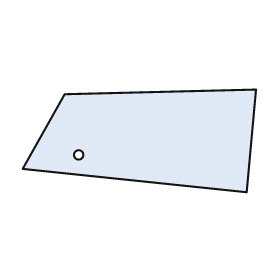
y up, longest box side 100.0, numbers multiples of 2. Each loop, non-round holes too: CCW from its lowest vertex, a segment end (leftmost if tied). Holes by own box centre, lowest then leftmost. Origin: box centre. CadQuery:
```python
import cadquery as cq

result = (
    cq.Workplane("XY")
    .moveTo(46.0, -22.0)
    .lineTo(50.0, 22.0)
    .lineTo(-32.0, 20.0)
    .lineTo(-50.0, -12.0)
    .close()
    .moveTo(-26.0, -6.0)
    .circle(2.0)
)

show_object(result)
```